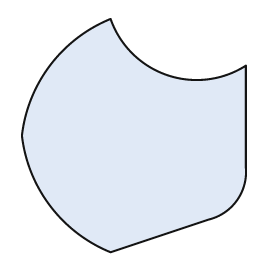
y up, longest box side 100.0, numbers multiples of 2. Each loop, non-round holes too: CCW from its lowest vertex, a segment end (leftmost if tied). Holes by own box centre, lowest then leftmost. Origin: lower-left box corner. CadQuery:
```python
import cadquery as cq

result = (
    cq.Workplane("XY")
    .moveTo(38.0, 0.0)
    .lineTo(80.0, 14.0)
    .threePointArc((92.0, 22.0), (96.0, 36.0))
    .lineTo(96.0, 80.0)
    .threePointArc((62.0, 76.0), (38.0, 100.0))
    .threePointArc((12.0, 80.0), (0.0, 50.0))
    .threePointArc((12.0, 20.0), (38.0, 0.0))
    .close()
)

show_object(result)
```